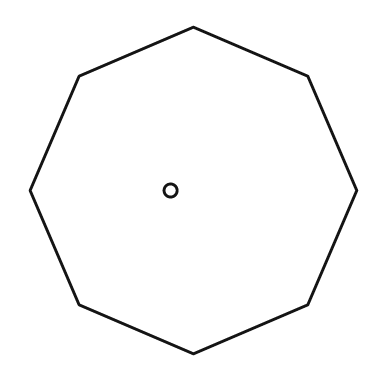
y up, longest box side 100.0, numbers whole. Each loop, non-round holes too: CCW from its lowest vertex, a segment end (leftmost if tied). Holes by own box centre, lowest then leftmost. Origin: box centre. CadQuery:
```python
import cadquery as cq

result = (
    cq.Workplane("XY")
    .moveTo(0.0, -50.0)
    .lineTo(35.0, -35.0)
    .lineTo(50.0, 0.0)
    .lineTo(35.0, 35.0)
    .lineTo(0.0, 50.0)
    .lineTo(-35.0, 35.0)
    .lineTo(-50.0, 0.0)
    .lineTo(-35.0, -35.0)
    .close()
    .moveTo(-7.0, 0.0)
    .circle(2.0)
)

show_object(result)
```